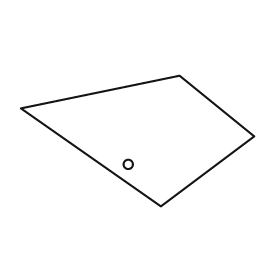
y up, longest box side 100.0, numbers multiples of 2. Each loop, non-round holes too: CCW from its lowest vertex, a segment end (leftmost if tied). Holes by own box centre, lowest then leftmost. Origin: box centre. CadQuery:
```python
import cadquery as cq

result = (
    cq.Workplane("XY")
    .moveTo(10.0, -28.0)
    .lineTo(50.0, 2.0)
    .lineTo(18.0, 28.0)
    .lineTo(-50.0, 14.0)
    .close()
    .moveTo(-4.0, -10.0)
    .circle(2.0)
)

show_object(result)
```